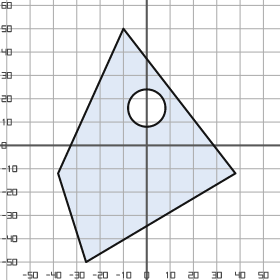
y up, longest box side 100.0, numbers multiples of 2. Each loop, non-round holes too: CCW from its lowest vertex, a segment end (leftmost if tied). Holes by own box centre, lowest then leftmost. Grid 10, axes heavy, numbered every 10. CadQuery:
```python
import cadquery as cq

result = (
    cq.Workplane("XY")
    .moveTo(-26.0, -50.0)
    .lineTo(38.0, -12.0)
    .lineTo(-10.0, 50.0)
    .lineTo(-38.0, -12.0)
    .close()
    .moveTo(0.0, 16.0)
    .circle(8.0)
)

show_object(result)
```